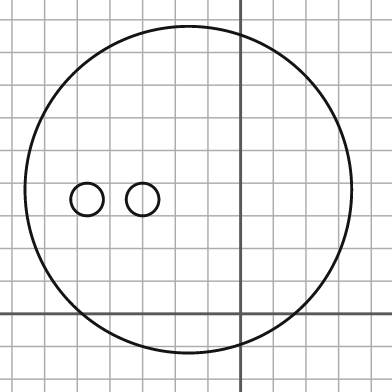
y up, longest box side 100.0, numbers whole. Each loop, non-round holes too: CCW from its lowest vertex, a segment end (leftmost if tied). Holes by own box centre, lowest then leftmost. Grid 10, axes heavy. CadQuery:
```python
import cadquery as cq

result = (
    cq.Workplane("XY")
    .moveTo(-16.0, 38.0)
    .circle(50.0)
    .moveTo(-47.0, 35.0)
    .circle(5.0)
    .moveTo(-30.0, 35.0)
    .circle(5.0)
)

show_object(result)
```